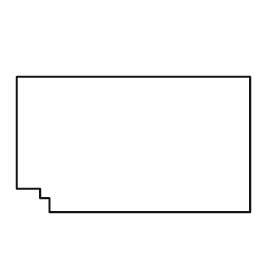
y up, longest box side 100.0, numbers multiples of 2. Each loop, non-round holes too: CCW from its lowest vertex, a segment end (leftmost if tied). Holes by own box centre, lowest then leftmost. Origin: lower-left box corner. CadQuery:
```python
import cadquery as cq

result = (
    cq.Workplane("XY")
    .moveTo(14.0, 0.0)
    .lineTo(100.0, 0.0)
    .lineTo(100.0, 58.0)
    .lineTo(0.0, 58.0)
    .lineTo(0.0, 10.0)
    .lineTo(10.0, 10.0)
    .lineTo(10.0, 6.0)
    .lineTo(14.0, 6.0)
    .close()
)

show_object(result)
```